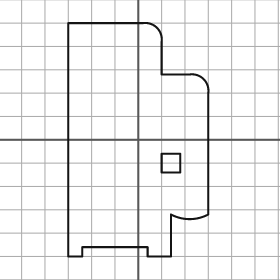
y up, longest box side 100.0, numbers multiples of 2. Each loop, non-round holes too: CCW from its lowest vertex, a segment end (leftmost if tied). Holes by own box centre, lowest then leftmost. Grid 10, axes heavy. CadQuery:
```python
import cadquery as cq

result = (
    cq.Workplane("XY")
    .moveTo(-30.0, -50.0)
    .lineTo(-24.0, -50.0)
    .lineTo(-24.0, -46.0)
    .lineTo(4.0, -46.0)
    .lineTo(4.0, -50.0)
    .lineTo(14.0, -50.0)
    .lineTo(14.0, -32.0)
    .threePointArc((22.0, -34.0), (30.0, -32.0))
    .lineTo(30.0, 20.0)
    .threePointArc((28.0, 26.0), (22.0, 28.0))
    .lineTo(10.0, 28.0)
    .lineTo(10.0, 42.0)
    .threePointArc((8.0, 48.0), (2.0, 50.0))
    .lineTo(-30.0, 50.0)
    .close()
    .moveTo(10.0, -14.0)
    .lineTo(18.0, -14.0)
    .lineTo(18.0, -6.0)
    .lineTo(10.0, -6.0)
    .close()
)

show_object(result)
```